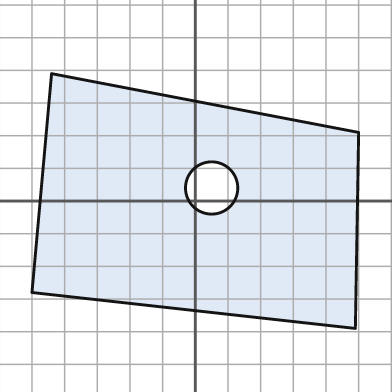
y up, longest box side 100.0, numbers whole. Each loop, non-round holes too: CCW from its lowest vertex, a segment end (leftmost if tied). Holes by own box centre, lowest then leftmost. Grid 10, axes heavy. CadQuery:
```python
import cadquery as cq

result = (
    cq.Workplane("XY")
    .moveTo(49.0, -39.0)
    .lineTo(50.0, 21.0)
    .lineTo(-44.0, 39.0)
    .lineTo(-50.0, -28.0)
    .close()
    .moveTo(5.0, 4.0)
    .circle(8.0)
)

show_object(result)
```